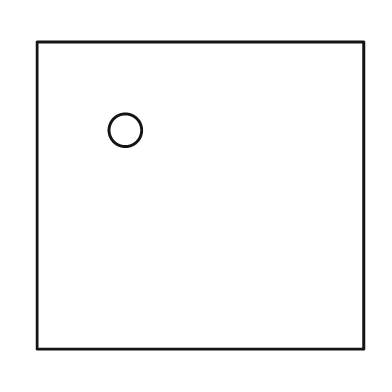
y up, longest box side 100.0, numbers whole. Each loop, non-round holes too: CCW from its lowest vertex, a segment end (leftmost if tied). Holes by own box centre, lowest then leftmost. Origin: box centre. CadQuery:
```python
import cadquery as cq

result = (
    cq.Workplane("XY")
    .moveTo(-50.0, -47.0)
    .lineTo(50.0, -47.0)
    .lineTo(50.0, 47.0)
    .lineTo(-50.0, 47.0)
    .close()
    .moveTo(-23.0, 20.0)
    .circle(5.0)
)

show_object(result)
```